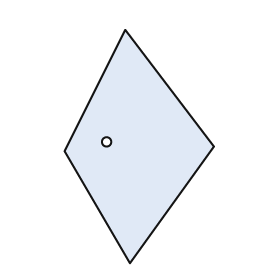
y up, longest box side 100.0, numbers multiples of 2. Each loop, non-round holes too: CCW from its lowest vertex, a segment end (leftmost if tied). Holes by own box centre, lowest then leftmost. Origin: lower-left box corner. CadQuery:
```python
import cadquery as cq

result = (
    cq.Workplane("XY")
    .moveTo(28.0, 0.0)
    .lineTo(64.0, 50.0)
    .lineTo(26.0, 100.0)
    .lineTo(0.0, 48.0)
    .close()
    .moveTo(18.0, 52.0)
    .circle(2.0)
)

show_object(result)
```